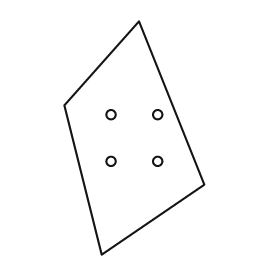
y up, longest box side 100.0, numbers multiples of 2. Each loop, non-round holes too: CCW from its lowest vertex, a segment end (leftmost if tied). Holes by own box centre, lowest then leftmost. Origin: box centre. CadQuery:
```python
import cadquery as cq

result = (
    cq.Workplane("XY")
    .moveTo(-14.0, -50.0)
    .lineTo(30.0, -20.0)
    .lineTo(2.0, 50.0)
    .lineTo(-30.0, 14.0)
    .close()
    .moveTo(-10.0, -10.0)
    .circle(2.0)
    .moveTo(10.0, -10.0)
    .circle(2.0)
    .moveTo(-10.0, 10.0)
    .circle(2.0)
    .moveTo(10.0, 10.0)
    .circle(2.0)
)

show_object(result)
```